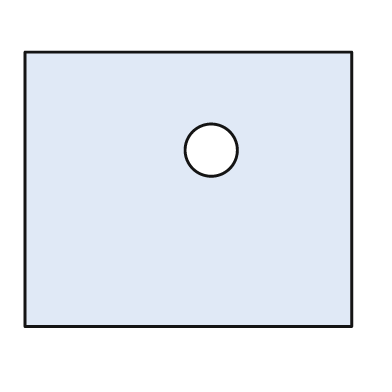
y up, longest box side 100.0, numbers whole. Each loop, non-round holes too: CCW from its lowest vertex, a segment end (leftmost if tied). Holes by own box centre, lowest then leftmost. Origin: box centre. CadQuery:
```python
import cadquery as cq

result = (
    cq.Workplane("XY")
    .moveTo(-50.0, -42.0)
    .lineTo(50.0, -42.0)
    .lineTo(50.0, 42.0)
    .lineTo(-50.0, 42.0)
    .close()
    .moveTo(7.0, 12.0)
    .circle(8.0)
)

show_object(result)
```